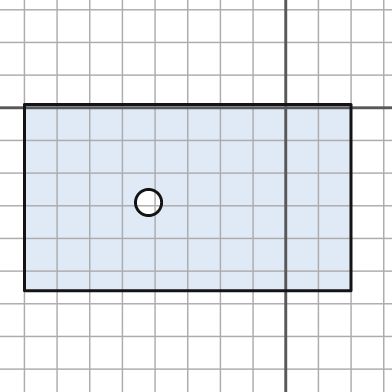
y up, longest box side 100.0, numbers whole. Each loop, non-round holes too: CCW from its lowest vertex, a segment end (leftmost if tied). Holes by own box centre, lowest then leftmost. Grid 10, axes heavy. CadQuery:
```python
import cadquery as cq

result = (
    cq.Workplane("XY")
    .moveTo(-80.0, -56.0)
    .lineTo(20.0, -56.0)
    .lineTo(20.0, 1.0)
    .lineTo(-80.0, 1.0)
    .close()
    .moveTo(-42.0, -29.0)
    .circle(4.0)
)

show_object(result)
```